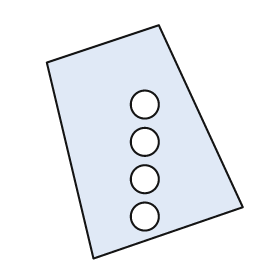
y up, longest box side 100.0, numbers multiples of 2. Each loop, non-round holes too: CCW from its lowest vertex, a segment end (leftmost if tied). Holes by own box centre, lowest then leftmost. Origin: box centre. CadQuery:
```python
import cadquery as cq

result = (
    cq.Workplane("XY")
    .moveTo(-22.0, -50.0)
    .lineTo(42.0, -28.0)
    .lineTo(6.0, 50.0)
    .lineTo(-42.0, 34.0)
    .close()
    .moveTo(0.0, -32.0)
    .circle(6.0)
    .moveTo(0.0, -16.0)
    .circle(6.0)
    .moveTo(0.0, 0.0)
    .circle(6.0)
    .moveTo(0.0, 16.0)
    .circle(6.0)
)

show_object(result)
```